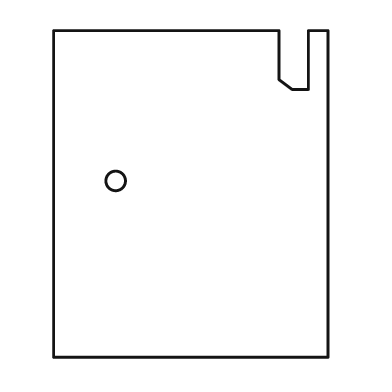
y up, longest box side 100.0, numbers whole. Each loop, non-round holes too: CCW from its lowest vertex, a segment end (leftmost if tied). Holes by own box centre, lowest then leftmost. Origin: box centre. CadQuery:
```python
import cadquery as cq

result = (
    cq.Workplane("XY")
    .moveTo(-42.0, -50.0)
    .lineTo(42.0, -50.0)
    .lineTo(42.0, 50.0)
    .lineTo(36.0, 50.0)
    .lineTo(36.0, 32.0)
    .lineTo(31.0, 32.0)
    .lineTo(27.0, 35.0)
    .lineTo(27.0, 50.0)
    .lineTo(-42.0, 50.0)
    .close()
    .moveTo(-23.0, 4.0)
    .circle(3.0)
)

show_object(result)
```